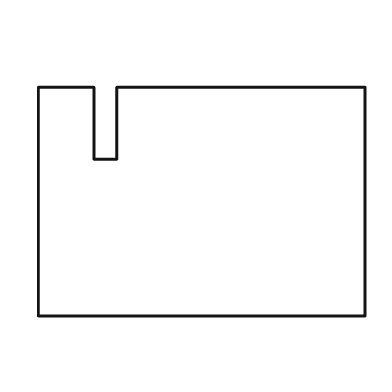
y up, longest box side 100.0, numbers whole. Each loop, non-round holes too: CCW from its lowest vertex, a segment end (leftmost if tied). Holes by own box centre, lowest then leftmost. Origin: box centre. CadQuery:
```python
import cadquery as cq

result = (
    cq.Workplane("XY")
    .moveTo(-50.0, -35.0)
    .lineTo(50.0, -35.0)
    .lineTo(50.0, 35.0)
    .lineTo(-26.0, 35.0)
    .lineTo(-26.0, 13.0)
    .lineTo(-33.0, 13.0)
    .lineTo(-33.0, 35.0)
    .lineTo(-50.0, 35.0)
    .close()
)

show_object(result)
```